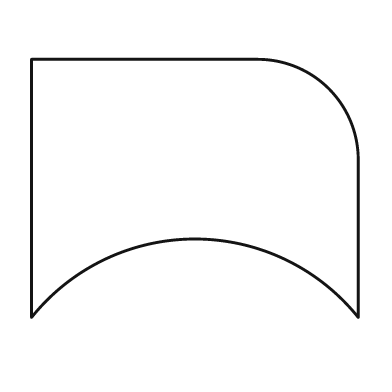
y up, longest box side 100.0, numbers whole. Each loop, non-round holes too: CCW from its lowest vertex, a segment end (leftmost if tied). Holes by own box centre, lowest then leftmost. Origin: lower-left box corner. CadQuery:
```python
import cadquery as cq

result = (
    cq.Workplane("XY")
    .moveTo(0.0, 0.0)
    .threePointArc((50.0, 24.0), (100.0, 0.0))
    .lineTo(100.0, 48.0)
    .threePointArc((91.0, 70.0), (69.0, 79.0))
    .lineTo(0.0, 79.0)
    .close()
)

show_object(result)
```